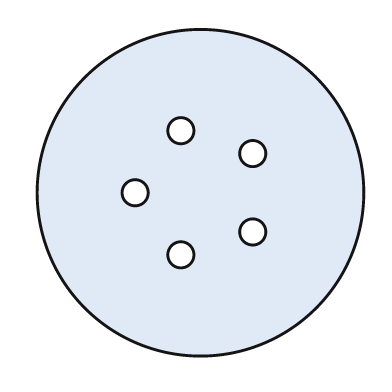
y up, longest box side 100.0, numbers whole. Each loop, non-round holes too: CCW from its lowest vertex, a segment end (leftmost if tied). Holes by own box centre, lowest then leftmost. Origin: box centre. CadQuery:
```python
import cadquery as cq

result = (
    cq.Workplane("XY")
    .moveTo(0.0, 0.0)
    .circle(50.0)
    .moveTo(-6.0, -19.0)
    .circle(4.0)
    .moveTo(16.0, -12.0)
    .circle(4.0)
    .moveTo(-20.0, 0.0)
    .circle(4.0)
    .moveTo(16.0, 12.0)
    .circle(4.0)
    .moveTo(-6.0, 19.0)
    .circle(4.0)
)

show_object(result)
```